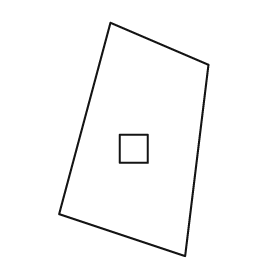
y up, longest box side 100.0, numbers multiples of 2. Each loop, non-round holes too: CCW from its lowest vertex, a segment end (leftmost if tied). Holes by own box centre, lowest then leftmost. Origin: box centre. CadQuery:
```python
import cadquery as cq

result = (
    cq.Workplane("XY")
    .moveTo(22.0, -50.0)
    .lineTo(32.0, 32.0)
    .lineTo(-10.0, 50.0)
    .lineTo(-32.0, -32.0)
    .close()
    .moveTo(-6.0, -10.0)
    .lineTo(6.0, -10.0)
    .lineTo(6.0, 2.0)
    .lineTo(-6.0, 2.0)
    .close()
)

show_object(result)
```